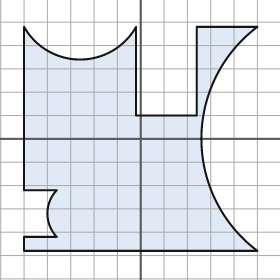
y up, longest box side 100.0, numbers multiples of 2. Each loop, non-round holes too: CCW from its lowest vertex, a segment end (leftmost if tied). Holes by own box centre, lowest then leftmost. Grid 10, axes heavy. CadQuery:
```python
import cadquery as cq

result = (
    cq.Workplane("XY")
    .moveTo(-50.0, -48.0)
    .lineTo(50.0, -48.0)
    .threePointArc((26.0, 0.0), (50.0, 48.0))
    .lineTo(24.0, 48.0)
    .lineTo(24.0, 10.0)
    .lineTo(-2.0, 10.0)
    .lineTo(-2.0, 48.0)
    .threePointArc((-26.0, 34.0), (-50.0, 48.0))
    .lineTo(-50.0, -22.0)
    .lineTo(-36.0, -22.0)
    .threePointArc((-40.0, -32.0), (-36.0, -42.0))
    .lineTo(-50.0, -42.0)
    .close()
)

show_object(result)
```